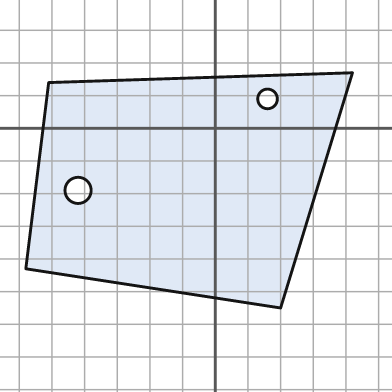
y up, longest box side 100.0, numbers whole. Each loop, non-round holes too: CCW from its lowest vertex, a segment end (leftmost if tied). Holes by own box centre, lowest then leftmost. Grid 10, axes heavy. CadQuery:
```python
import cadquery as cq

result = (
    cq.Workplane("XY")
    .moveTo(20.0, -55.0)
    .lineTo(42.0, 17.0)
    .lineTo(-51.0, 14.0)
    .lineTo(-58.0, -43.0)
    .close()
    .moveTo(-42.0, -19.0)
    .circle(4.0)
    .moveTo(16.0, 9.0)
    .circle(3.0)
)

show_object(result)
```